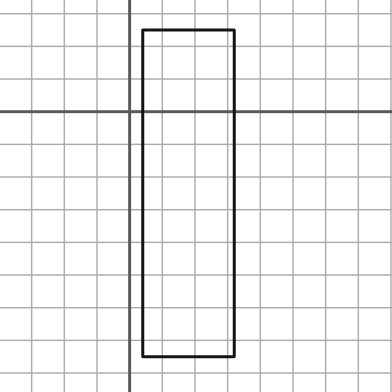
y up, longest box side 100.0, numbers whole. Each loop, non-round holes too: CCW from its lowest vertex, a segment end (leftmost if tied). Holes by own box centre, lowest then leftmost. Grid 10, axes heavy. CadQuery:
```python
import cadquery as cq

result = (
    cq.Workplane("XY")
    .moveTo(4.0, -75.0)
    .lineTo(32.0, -75.0)
    .lineTo(32.0, 25.0)
    .lineTo(4.0, 25.0)
    .close()
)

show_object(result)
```